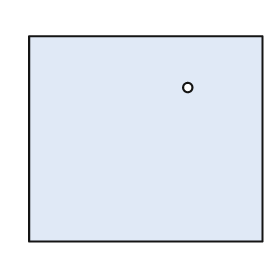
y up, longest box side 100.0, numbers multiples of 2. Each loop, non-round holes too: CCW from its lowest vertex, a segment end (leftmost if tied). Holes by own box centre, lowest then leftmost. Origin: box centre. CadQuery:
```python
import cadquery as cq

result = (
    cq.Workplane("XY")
    .moveTo(-50.0, -44.0)
    .lineTo(50.0, -44.0)
    .lineTo(50.0, 44.0)
    .lineTo(-50.0, 44.0)
    .close()
    .moveTo(18.0, 22.0)
    .circle(2.0)
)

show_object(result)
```